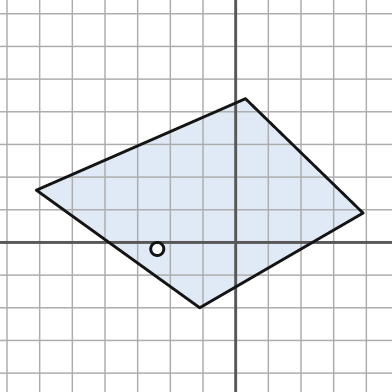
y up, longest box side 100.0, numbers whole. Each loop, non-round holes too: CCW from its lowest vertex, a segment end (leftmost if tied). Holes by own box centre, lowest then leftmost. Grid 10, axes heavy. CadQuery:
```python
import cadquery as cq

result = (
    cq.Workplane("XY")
    .moveTo(-11.0, -20.0)
    .lineTo(39.0, 9.0)
    .lineTo(3.0, 44.0)
    .lineTo(-61.0, 16.0)
    .close()
    .moveTo(-24.0, -2.0)
    .circle(2.0)
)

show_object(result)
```